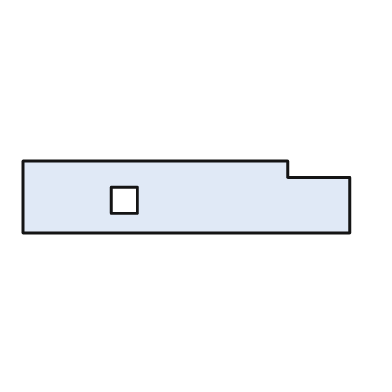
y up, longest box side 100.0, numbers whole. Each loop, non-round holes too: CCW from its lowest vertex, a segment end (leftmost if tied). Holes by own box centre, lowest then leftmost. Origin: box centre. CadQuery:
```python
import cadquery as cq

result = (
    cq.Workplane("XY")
    .moveTo(-50.0, -11.0)
    .lineTo(50.0, -11.0)
    .lineTo(50.0, 6.0)
    .lineTo(31.0, 6.0)
    .lineTo(31.0, 11.0)
    .lineTo(-50.0, 11.0)
    .close()
    .moveTo(-23.0, -5.0)
    .lineTo(-15.0, -5.0)
    .lineTo(-15.0, 3.0)
    .lineTo(-23.0, 3.0)
    .close()
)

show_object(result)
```